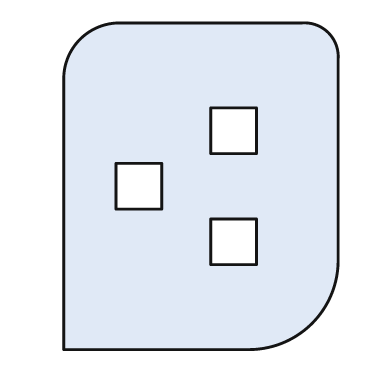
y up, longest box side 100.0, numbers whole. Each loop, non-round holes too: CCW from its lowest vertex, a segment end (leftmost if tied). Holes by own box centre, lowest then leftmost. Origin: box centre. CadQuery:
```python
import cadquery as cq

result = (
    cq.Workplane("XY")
    .moveTo(-42.0, -50.0)
    .lineTo(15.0, -50.0)
    .threePointArc((34.0, -42.0), (42.0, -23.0))
    .lineTo(42.0, 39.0)
    .threePointArc((39.0, 47.0), (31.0, 50.0))
    .lineTo(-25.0, 50.0)
    .threePointArc((-37.0, 45.0), (-42.0, 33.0))
    .close()
    .moveTo(3.0, -24.0)
    .lineTo(17.0, -24.0)
    .lineTo(17.0, -10.0)
    .lineTo(3.0, -10.0)
    .close()
    .moveTo(-26.0, -7.0)
    .lineTo(-12.0, -7.0)
    .lineTo(-12.0, 7.0)
    .lineTo(-26.0, 7.0)
    .close()
    .moveTo(3.0, 10.0)
    .lineTo(17.0, 10.0)
    .lineTo(17.0, 24.0)
    .lineTo(3.0, 24.0)
    .close()
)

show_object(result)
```